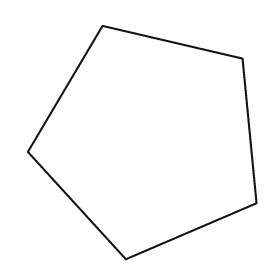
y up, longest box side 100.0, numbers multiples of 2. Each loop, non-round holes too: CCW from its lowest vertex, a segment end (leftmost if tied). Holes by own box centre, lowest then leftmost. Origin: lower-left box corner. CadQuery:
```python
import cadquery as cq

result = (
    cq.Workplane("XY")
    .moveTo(42.0, 0.0)
    .lineTo(98.0, 24.0)
    .lineTo(92.0, 86.0)
    .lineTo(32.0, 100.0)
    .lineTo(0.0, 46.0)
    .close()
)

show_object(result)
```